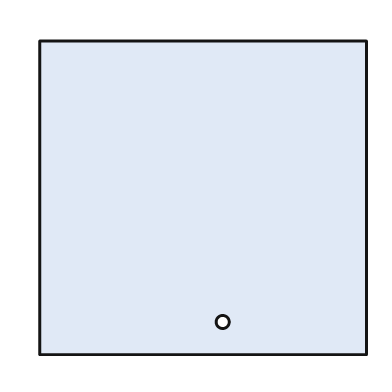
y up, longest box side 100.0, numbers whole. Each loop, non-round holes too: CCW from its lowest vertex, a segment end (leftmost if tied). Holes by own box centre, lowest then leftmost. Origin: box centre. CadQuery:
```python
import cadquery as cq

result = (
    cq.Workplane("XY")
    .moveTo(-50.0, -48.0)
    .lineTo(50.0, -48.0)
    .lineTo(50.0, 48.0)
    .lineTo(-50.0, 48.0)
    .close()
    .moveTo(6.0, -38.0)
    .circle(2.0)
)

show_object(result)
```